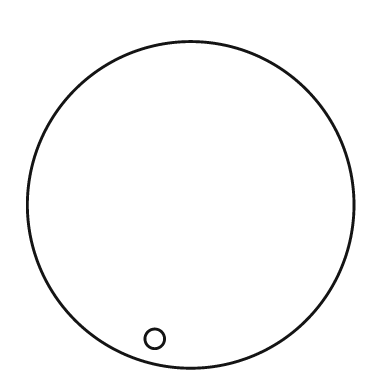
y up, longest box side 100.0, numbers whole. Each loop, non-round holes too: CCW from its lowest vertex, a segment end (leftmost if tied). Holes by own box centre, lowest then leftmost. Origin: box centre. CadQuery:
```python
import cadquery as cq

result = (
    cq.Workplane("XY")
    .moveTo(0.0, 0.0)
    .circle(50.0)
    .moveTo(-11.0, -41.0)
    .circle(3.0)
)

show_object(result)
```